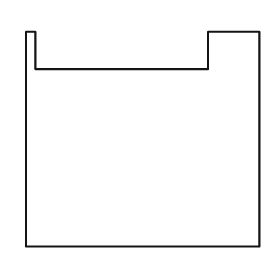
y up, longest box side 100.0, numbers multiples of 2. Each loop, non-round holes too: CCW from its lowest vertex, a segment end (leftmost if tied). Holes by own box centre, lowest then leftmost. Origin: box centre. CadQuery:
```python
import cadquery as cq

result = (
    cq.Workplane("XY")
    .moveTo(-50.0, -46.0)
    .lineTo(50.0, -46.0)
    .lineTo(50.0, 46.0)
    .lineTo(28.0, 46.0)
    .lineTo(28.0, 30.0)
    .lineTo(-46.0, 30.0)
    .lineTo(-46.0, 46.0)
    .lineTo(-50.0, 46.0)
    .close()
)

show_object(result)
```